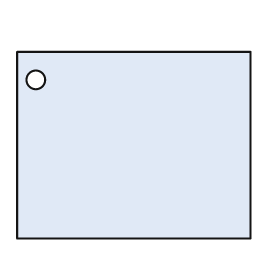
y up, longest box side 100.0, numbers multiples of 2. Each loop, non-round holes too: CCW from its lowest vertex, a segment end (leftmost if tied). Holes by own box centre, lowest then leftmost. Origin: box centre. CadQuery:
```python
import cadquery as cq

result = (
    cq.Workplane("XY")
    .moveTo(-50.0, -40.0)
    .lineTo(50.0, -40.0)
    .lineTo(50.0, 40.0)
    .lineTo(-50.0, 40.0)
    .close()
    .moveTo(-42.0, 28.0)
    .circle(4.0)
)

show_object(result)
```